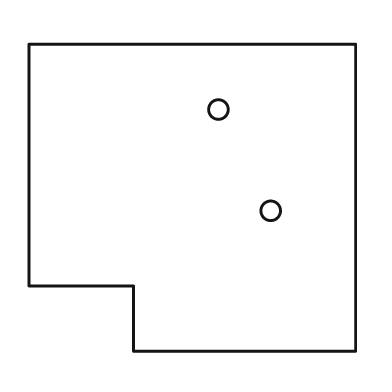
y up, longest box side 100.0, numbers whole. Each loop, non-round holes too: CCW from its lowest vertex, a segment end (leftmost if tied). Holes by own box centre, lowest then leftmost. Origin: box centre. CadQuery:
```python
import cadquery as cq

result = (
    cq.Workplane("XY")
    .moveTo(-18.0, -47.0)
    .lineTo(50.0, -47.0)
    .lineTo(50.0, 47.0)
    .lineTo(-50.0, 47.0)
    .lineTo(-50.0, -27.0)
    .lineTo(-18.0, -27.0)
    .close()
    .moveTo(24.0, -4.0)
    .circle(3.0)
    .moveTo(8.0, 27.0)
    .circle(3.0)
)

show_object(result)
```